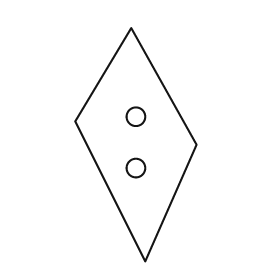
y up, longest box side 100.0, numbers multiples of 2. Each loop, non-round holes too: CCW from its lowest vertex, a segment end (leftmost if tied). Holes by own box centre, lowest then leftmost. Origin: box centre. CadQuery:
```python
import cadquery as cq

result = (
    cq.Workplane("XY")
    .moveTo(4.0, -50.0)
    .lineTo(26.0, 0.0)
    .lineTo(-2.0, 50.0)
    .lineTo(-26.0, 10.0)
    .close()
    .moveTo(0.0, -10.0)
    .circle(4.0)
    .moveTo(0.0, 12.0)
    .circle(4.0)
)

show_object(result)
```